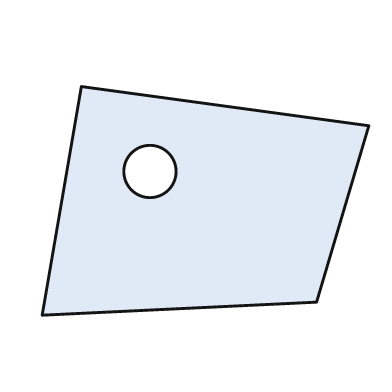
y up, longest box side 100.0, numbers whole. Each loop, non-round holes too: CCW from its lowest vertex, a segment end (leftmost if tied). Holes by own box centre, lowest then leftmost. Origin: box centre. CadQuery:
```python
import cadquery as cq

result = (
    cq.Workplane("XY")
    .moveTo(-50.0, -35.0)
    .lineTo(34.0, -31.0)
    .lineTo(50.0, 23.0)
    .lineTo(-38.0, 35.0)
    .close()
    .moveTo(-17.0, 9.0)
    .circle(8.0)
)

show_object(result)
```